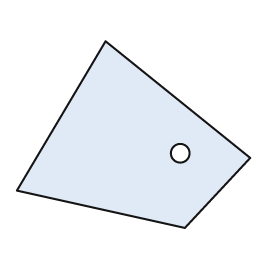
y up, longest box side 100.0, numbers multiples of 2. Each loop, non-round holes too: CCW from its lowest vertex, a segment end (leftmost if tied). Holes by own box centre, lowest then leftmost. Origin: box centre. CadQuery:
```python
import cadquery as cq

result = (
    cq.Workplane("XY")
    .moveTo(22.0, -40.0)
    .lineTo(50.0, -10.0)
    .lineTo(-12.0, 40.0)
    .lineTo(-50.0, -24.0)
    .close()
    .moveTo(20.0, -8.0)
    .circle(4.0)
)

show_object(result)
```